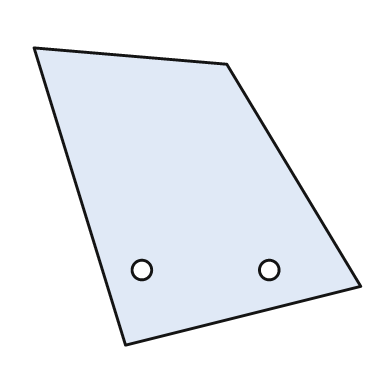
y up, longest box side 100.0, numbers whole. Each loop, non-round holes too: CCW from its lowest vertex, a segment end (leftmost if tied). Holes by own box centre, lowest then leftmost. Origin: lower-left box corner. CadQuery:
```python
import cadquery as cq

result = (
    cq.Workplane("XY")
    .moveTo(28.0, 0.0)
    .lineTo(100.0, 18.0)
    .lineTo(59.0, 86.0)
    .lineTo(0.0, 91.0)
    .close()
    .moveTo(33.0, 23.0)
    .circle(3.0)
    .moveTo(72.0, 23.0)
    .circle(3.0)
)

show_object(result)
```